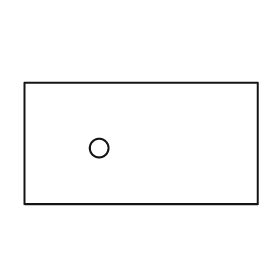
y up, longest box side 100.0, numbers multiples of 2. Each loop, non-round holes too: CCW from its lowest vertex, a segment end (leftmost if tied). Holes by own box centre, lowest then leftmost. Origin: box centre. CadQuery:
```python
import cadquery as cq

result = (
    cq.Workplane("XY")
    .moveTo(-50.0, -26.0)
    .lineTo(50.0, -26.0)
    .lineTo(50.0, 26.0)
    .lineTo(-50.0, 26.0)
    .close()
    .moveTo(-18.0, -2.0)
    .circle(4.0)
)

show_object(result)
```